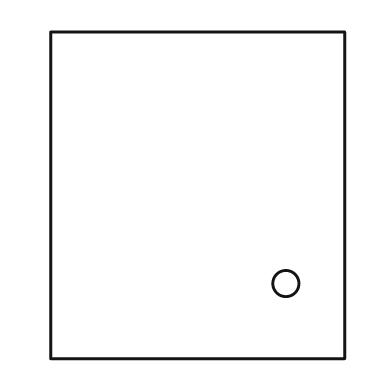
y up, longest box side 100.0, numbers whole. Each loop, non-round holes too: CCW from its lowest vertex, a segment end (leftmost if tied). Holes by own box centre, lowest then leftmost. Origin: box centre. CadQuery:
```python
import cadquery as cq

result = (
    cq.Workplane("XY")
    .moveTo(-45.0, -50.0)
    .lineTo(45.0, -50.0)
    .lineTo(45.0, 50.0)
    .lineTo(-45.0, 50.0)
    .close()
    .moveTo(27.0, -27.0)
    .circle(4.0)
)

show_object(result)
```